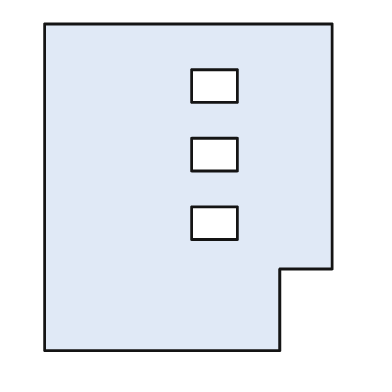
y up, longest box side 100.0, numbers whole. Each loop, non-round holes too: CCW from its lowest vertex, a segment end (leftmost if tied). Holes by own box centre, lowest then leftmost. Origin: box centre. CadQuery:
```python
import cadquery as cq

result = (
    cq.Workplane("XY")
    .moveTo(-44.0, -50.0)
    .lineTo(28.0, -50.0)
    .lineTo(28.0, -25.0)
    .lineTo(44.0, -25.0)
    .lineTo(44.0, 50.0)
    .lineTo(-44.0, 50.0)
    .close()
    .moveTo(1.0, -16.0)
    .lineTo(15.0, -16.0)
    .lineTo(15.0, -6.0)
    .lineTo(1.0, -6.0)
    .close()
    .moveTo(1.0, 5.0)
    .lineTo(15.0, 5.0)
    .lineTo(15.0, 15.0)
    .lineTo(1.0, 15.0)
    .close()
    .moveTo(1.0, 26.0)
    .lineTo(15.0, 26.0)
    .lineTo(15.0, 36.0)
    .lineTo(1.0, 36.0)
    .close()
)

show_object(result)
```